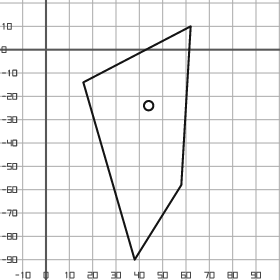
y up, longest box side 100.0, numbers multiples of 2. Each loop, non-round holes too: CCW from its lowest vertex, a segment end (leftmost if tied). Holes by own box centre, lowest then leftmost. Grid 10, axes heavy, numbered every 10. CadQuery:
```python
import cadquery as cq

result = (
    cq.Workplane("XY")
    .moveTo(38.0, -90.0)
    .lineTo(58.0, -58.0)
    .lineTo(62.0, 10.0)
    .lineTo(16.0, -14.0)
    .close()
    .moveTo(44.0, -24.0)
    .circle(2.0)
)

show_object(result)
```